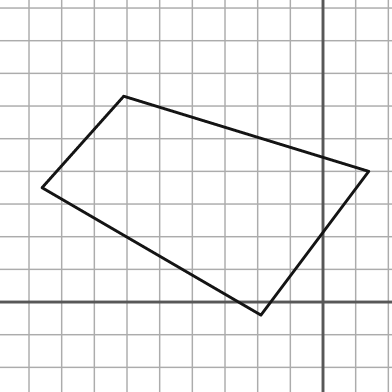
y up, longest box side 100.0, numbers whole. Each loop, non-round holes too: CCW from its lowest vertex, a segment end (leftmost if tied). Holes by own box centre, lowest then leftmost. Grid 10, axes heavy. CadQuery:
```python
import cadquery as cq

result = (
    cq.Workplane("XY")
    .moveTo(-19.0, -4.0)
    .lineTo(14.0, 40.0)
    .lineTo(-61.0, 63.0)
    .lineTo(-86.0, 35.0)
    .close()
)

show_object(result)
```